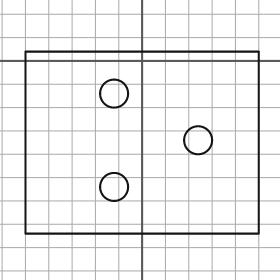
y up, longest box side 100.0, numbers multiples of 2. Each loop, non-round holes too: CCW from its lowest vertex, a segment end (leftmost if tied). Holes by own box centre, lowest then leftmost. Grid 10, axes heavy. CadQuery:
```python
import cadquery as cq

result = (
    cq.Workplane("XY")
    .moveTo(-50.0, -74.0)
    .lineTo(50.0, -74.0)
    .lineTo(50.0, 4.0)
    .lineTo(-50.0, 4.0)
    .close()
    .moveTo(-12.0, -54.0)
    .circle(6.0)
    .moveTo(24.0, -34.0)
    .circle(6.0)
    .moveTo(-12.0, -14.0)
    .circle(6.0)
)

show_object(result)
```